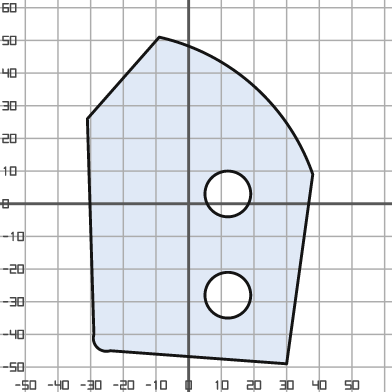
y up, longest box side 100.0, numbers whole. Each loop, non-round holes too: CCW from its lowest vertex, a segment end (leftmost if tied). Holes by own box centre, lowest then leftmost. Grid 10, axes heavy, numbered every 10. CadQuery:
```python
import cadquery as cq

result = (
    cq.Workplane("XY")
    .moveTo(30.0, -49.0)
    .lineTo(38.0, 9.0)
    .threePointArc((20.0, 36.0), (-9.0, 51.0))
    .lineTo(-31.0, 26.0)
    .lineTo(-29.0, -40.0)
    .threePointArc((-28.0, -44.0), (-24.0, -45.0))
    .close()
    .moveTo(12.0, -28.0)
    .circle(7.0)
    .moveTo(12.0, 3.0)
    .circle(7.0)
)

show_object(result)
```